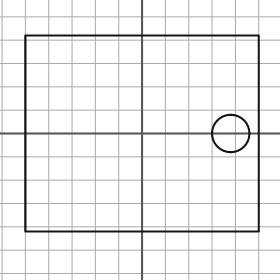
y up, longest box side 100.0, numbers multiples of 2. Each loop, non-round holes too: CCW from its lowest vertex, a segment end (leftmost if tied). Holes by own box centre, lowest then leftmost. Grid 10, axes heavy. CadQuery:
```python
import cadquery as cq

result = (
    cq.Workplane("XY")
    .moveTo(-50.0, -42.0)
    .lineTo(50.0, -42.0)
    .lineTo(50.0, 42.0)
    .lineTo(-50.0, 42.0)
    .close()
    .moveTo(38.0, 0.0)
    .circle(8.0)
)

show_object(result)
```